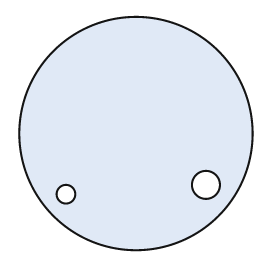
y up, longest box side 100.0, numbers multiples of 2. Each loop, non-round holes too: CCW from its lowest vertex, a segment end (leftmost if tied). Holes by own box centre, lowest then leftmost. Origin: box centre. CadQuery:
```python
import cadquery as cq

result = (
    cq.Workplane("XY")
    .moveTo(0.0, 0.0)
    .circle(50.0)
    .moveTo(-30.0, -26.0)
    .circle(4.0)
    .moveTo(30.0, -22.0)
    .circle(6.0)
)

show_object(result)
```